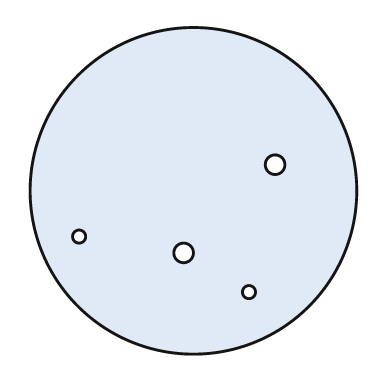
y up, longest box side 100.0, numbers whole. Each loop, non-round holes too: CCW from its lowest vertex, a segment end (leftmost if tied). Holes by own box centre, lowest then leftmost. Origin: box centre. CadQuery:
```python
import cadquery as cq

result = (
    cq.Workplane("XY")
    .moveTo(0.0, 0.0)
    .circle(50.0)
    .moveTo(17.0, -31.0)
    .circle(2.0)
    .moveTo(-3.0, -19.0)
    .circle(3.0)
    .moveTo(-35.0, -14.0)
    .circle(2.0)
    .moveTo(25.0, 8.0)
    .circle(3.0)
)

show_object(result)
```